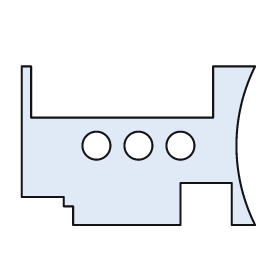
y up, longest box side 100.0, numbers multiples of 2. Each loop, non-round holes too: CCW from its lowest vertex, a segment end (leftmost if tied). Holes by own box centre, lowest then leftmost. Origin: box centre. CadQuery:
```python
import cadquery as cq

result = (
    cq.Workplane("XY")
    .moveTo(-28.0, -34.0)
    .lineTo(18.0, -34.0)
    .lineTo(18.0, -16.0)
    .lineTo(40.0, -16.0)
    .lineTo(40.0, -34.0)
    .lineTo(50.0, -34.0)
    .threePointArc((42.0, 0.0), (50.0, 34.0))
    .lineTo(32.0, 34.0)
    .lineTo(32.0, 12.0)
    .lineTo(-46.0, 12.0)
    .lineTo(-46.0, 34.0)
    .lineTo(-50.0, 34.0)
    .lineTo(-50.0, -22.0)
    .lineTo(-32.0, -22.0)
    .lineTo(-32.0, -26.0)
    .lineTo(-28.0, -26.0)
    .close()
    .moveTo(-18.0, 0.0)
    .circle(6.0)
    .moveTo(0.0, 0.0)
    .circle(6.0)
    .moveTo(18.0, 0.0)
    .circle(6.0)
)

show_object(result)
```